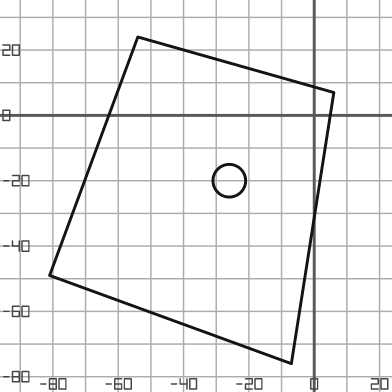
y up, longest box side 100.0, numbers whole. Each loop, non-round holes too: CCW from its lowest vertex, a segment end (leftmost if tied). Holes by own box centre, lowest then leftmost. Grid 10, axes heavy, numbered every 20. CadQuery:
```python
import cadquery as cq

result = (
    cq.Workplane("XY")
    .moveTo(-7.0, -76.0)
    .lineTo(6.0, 7.0)
    .lineTo(-54.0, 24.0)
    .lineTo(-81.0, -49.0)
    .close()
    .moveTo(-26.0, -20.0)
    .circle(5.0)
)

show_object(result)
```